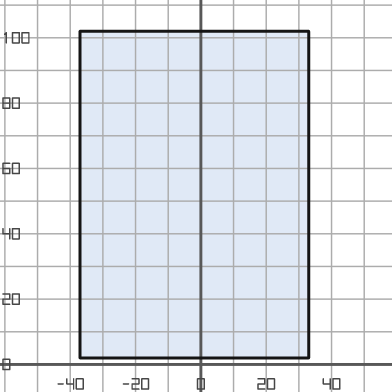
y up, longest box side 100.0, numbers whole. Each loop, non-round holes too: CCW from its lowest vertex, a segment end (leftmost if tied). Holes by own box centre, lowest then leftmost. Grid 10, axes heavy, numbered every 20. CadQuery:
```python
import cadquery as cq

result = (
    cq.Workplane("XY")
    .moveTo(-37.0, 2.0)
    .lineTo(33.0, 2.0)
    .lineTo(33.0, 102.0)
    .lineTo(-37.0, 102.0)
    .close()
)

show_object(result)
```